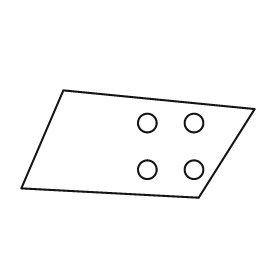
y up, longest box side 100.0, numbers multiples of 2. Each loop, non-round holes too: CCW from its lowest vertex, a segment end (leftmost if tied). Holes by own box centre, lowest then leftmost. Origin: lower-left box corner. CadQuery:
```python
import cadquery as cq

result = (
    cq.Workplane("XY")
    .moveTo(76.0, 0.0)
    .lineTo(100.0, 38.0)
    .lineTo(18.0, 46.0)
    .lineTo(0.0, 4.0)
    .close()
    .moveTo(54.0, 12.0)
    .circle(4.0)
    .moveTo(74.0, 12.0)
    .circle(4.0)
    .moveTo(54.0, 32.0)
    .circle(4.0)
    .moveTo(74.0, 32.0)
    .circle(4.0)
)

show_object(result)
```